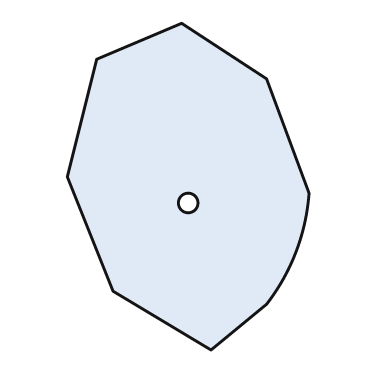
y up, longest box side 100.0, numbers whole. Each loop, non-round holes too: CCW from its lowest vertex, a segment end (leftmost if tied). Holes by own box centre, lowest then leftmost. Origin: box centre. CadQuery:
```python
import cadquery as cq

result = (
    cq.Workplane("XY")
    .moveTo(7.0, -50.0)
    .lineTo(24.0, -36.0)
    .threePointArc((33.0, -20.0), (37.0, -2.0))
    .lineTo(24.0, 33.0)
    .lineTo(-2.0, 50.0)
    .lineTo(-28.0, 39.0)
    .lineTo(-37.0, 3.0)
    .lineTo(-23.0, -32.0)
    .close()
    .moveTo(0.0, -5.0)
    .circle(3.0)
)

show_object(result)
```